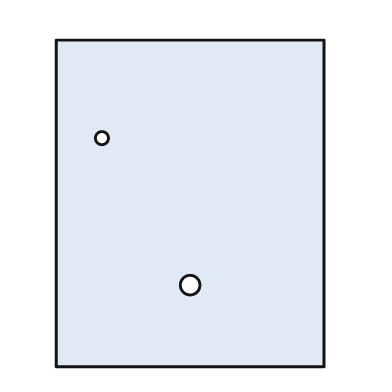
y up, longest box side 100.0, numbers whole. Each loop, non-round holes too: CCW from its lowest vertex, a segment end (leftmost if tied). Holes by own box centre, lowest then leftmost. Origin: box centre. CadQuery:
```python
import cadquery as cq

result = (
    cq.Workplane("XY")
    .moveTo(-41.0, -50.0)
    .lineTo(41.0, -50.0)
    .lineTo(41.0, 50.0)
    .lineTo(-41.0, 50.0)
    .close()
    .moveTo(0.0, -25.0)
    .circle(3.0)
    .moveTo(-27.0, 20.0)
    .circle(2.0)
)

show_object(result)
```